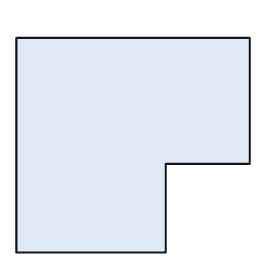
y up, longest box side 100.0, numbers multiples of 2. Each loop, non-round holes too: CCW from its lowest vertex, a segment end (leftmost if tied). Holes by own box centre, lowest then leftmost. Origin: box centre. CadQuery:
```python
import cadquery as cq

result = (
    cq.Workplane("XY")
    .moveTo(-50.0, -46.0)
    .lineTo(14.0, -46.0)
    .lineTo(14.0, -8.0)
    .lineTo(50.0, -8.0)
    .lineTo(50.0, 46.0)
    .lineTo(-50.0, 46.0)
    .close()
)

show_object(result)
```